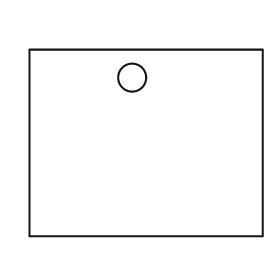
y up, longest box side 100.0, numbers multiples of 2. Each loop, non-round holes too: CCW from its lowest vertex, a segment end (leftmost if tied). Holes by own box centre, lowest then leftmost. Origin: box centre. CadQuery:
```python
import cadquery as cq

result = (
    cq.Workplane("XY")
    .moveTo(-50.0, -40.0)
    .lineTo(50.0, -40.0)
    .lineTo(50.0, 40.0)
    .lineTo(-50.0, 40.0)
    .close()
    .moveTo(-6.0, 28.0)
    .circle(6.0)
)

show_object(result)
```